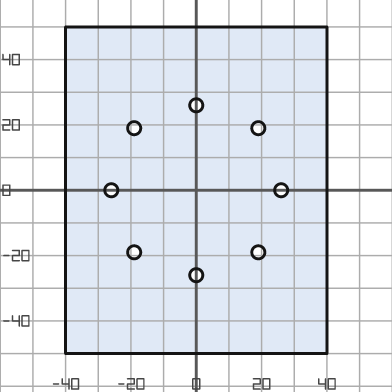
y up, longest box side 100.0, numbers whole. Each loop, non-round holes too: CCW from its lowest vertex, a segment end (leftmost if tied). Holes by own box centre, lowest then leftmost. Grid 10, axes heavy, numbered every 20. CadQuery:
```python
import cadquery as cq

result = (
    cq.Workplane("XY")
    .moveTo(-40.0, -50.0)
    .lineTo(40.0, -50.0)
    .lineTo(40.0, 50.0)
    .lineTo(-40.0, 50.0)
    .close()
    .moveTo(0.0, -26.0)
    .circle(2.0)
    .moveTo(-19.0, -19.0)
    .circle(2.0)
    .moveTo(19.0, -19.0)
    .circle(2.0)
    .moveTo(-26.0, 0.0)
    .circle(2.0)
    .moveTo(26.0, 0.0)
    .circle(2.0)
    .moveTo(-19.0, 19.0)
    .circle(2.0)
    .moveTo(19.0, 19.0)
    .circle(2.0)
    .moveTo(0.0, 26.0)
    .circle(2.0)
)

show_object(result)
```